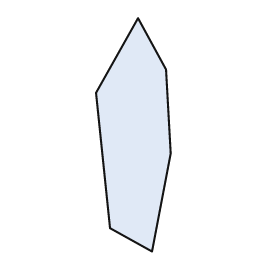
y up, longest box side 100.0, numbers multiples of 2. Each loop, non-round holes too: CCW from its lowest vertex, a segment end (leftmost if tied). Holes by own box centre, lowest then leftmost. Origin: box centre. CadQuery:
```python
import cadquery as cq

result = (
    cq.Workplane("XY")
    .moveTo(8.0, -50.0)
    .lineTo(16.0, -8.0)
    .lineTo(14.0, 28.0)
    .lineTo(2.0, 50.0)
    .lineTo(-16.0, 18.0)
    .lineTo(-10.0, -40.0)
    .close()
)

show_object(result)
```